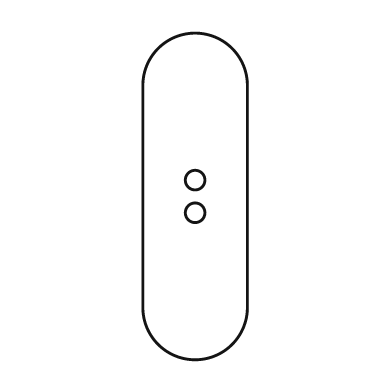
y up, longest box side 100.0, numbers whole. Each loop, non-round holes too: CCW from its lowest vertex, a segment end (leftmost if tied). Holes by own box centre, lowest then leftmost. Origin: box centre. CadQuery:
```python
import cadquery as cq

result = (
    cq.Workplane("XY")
    .moveTo(-16.0, -34.0)
    .threePointArc((0.0, -50.0), (16.0, -34.0))
    .lineTo(16.0, 34.0)
    .threePointArc((0.0, 50.0), (-16.0, 34.0))
    .close()
    .moveTo(0.0, -5.0)
    .circle(3.0)
    .moveTo(0.0, 5.0)
    .circle(3.0)
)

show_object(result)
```